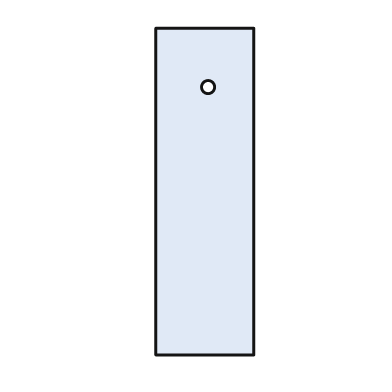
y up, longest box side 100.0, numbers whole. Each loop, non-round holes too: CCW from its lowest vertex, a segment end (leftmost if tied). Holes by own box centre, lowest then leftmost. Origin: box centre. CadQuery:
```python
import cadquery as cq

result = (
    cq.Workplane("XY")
    .moveTo(-15.0, -50.0)
    .lineTo(15.0, -50.0)
    .lineTo(15.0, 50.0)
    .lineTo(-15.0, 50.0)
    .close()
    .moveTo(1.0, 32.0)
    .circle(2.0)
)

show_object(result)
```